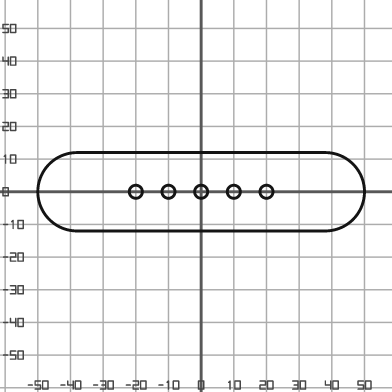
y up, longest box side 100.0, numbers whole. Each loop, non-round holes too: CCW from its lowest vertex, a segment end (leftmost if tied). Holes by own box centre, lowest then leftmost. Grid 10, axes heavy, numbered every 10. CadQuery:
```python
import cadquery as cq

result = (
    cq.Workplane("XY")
    .moveTo(-38.0, -12.0)
    .lineTo(38.0, -12.0)
    .threePointArc((50.0, 0.0), (38.0, 12.0))
    .lineTo(-38.0, 12.0)
    .threePointArc((-50.0, 0.0), (-38.0, -12.0))
    .close()
    .moveTo(-20.0, 0.0)
    .circle(2.0)
    .moveTo(-10.0, 0.0)
    .circle(2.0)
    .moveTo(0.0, 0.0)
    .circle(2.0)
    .moveTo(10.0, 0.0)
    .circle(2.0)
    .moveTo(20.0, 0.0)
    .circle(2.0)
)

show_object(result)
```